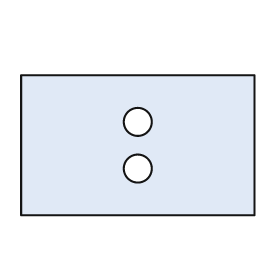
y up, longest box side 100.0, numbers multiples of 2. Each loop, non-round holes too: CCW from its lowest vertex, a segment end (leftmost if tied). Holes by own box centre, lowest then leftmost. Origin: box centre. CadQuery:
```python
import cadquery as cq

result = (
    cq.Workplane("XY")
    .moveTo(-50.0, -30.0)
    .lineTo(50.0, -30.0)
    .lineTo(50.0, 30.0)
    .lineTo(-50.0, 30.0)
    .close()
    .moveTo(0.0, -10.0)
    .circle(6.0)
    .moveTo(0.0, 10.0)
    .circle(6.0)
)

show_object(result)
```